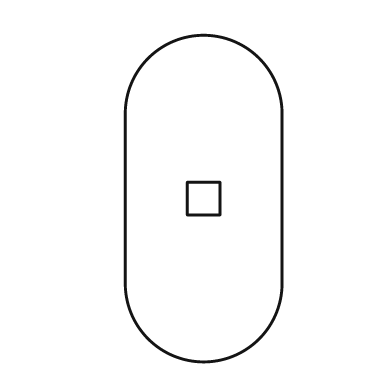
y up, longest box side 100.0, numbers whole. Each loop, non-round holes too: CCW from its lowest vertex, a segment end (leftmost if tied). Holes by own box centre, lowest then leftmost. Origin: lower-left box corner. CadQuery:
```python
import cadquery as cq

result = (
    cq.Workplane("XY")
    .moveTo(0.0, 24.0)
    .threePointArc((24.0, 0.0), (48.0, 24.0))
    .lineTo(48.0, 76.0)
    .threePointArc((24.0, 100.0), (0.0, 76.0))
    .close()
    .moveTo(19.0, 45.0)
    .lineTo(29.0, 45.0)
    .lineTo(29.0, 55.0)
    .lineTo(19.0, 55.0)
    .close()
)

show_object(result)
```